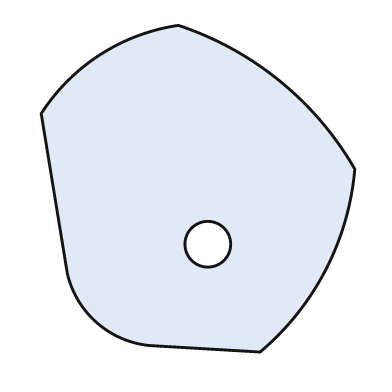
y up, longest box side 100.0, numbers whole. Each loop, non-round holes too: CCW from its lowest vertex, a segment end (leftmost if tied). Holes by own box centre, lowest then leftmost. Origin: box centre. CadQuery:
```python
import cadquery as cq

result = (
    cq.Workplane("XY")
    .moveTo(19.0, -50.0)
    .threePointArc((39.0, -25.0), (48.0, 6.0))
    .threePointArc((25.0, 33.0), (-6.0, 50.0))
    .threePointArc((-30.0, 41.0), (-48.0, 23.0))
    .lineTo(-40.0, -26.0)
    .threePointArc((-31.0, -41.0), (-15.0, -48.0))
    .close()
    .moveTo(3.0, -17.0)
    .circle(7.0)
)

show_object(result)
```